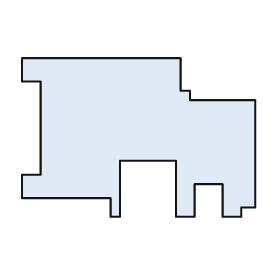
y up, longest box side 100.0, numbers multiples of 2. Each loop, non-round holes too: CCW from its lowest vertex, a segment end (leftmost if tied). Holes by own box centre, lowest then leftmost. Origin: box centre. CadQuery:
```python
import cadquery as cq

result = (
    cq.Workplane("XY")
    .moveTo(-12.0, -34.0)
    .lineTo(-8.0, -34.0)
    .lineTo(-8.0, -10.0)
    .lineTo(16.0, -10.0)
    .lineTo(16.0, -34.0)
    .lineTo(24.0, -34.0)
    .lineTo(24.0, -20.0)
    .lineTo(36.0, -20.0)
    .lineTo(36.0, -34.0)
    .lineTo(44.0, -34.0)
    .lineTo(44.0, -30.0)
    .lineTo(50.0, -30.0)
    .lineTo(50.0, 16.0)
    .lineTo(22.0, 16.0)
    .lineTo(22.0, 20.0)
    .lineTo(18.0, 20.0)
    .lineTo(18.0, 34.0)
    .lineTo(-50.0, 34.0)
    .lineTo(-50.0, 24.0)
    .lineTo(-42.0, 24.0)
    .lineTo(-42.0, -16.0)
    .lineTo(-50.0, -16.0)
    .lineTo(-50.0, -26.0)
    .lineTo(-12.0, -26.0)
    .close()
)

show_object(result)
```